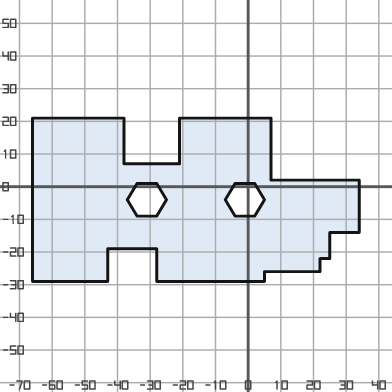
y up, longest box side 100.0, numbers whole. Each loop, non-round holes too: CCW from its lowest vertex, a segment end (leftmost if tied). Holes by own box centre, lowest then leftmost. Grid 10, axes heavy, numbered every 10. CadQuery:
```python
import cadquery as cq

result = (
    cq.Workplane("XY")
    .moveTo(-66.0, -29.0)
    .lineTo(-43.0, -29.0)
    .lineTo(-43.0, -19.0)
    .lineTo(-28.0, -19.0)
    .lineTo(-28.0, -29.0)
    .lineTo(5.0, -29.0)
    .lineTo(5.0, -26.0)
    .lineTo(22.0, -26.0)
    .lineTo(22.0, -22.0)
    .lineTo(25.0, -22.0)
    .lineTo(25.0, -14.0)
    .lineTo(34.0, -14.0)
    .lineTo(34.0, 2.0)
    .lineTo(7.0, 2.0)
    .lineTo(7.0, 21.0)
    .lineTo(-21.0, 21.0)
    .lineTo(-21.0, 7.0)
    .lineTo(-38.0, 7.0)
    .lineTo(-38.0, 21.0)
    .lineTo(-66.0, 21.0)
    .close()
    .moveTo(-34.0, -9.0)
    .lineTo(-28.0, -9.0)
    .lineTo(-25.0, -4.0)
    .lineTo(-28.0, 1.0)
    .lineTo(-34.0, 1.0)
    .lineTo(-37.0, -4.0)
    .close()
    .moveTo(-4.0, -9.0)
    .lineTo(2.0, -9.0)
    .lineTo(5.0, -4.0)
    .lineTo(2.0, 1.0)
    .lineTo(-4.0, 1.0)
    .lineTo(-7.0, -4.0)
    .close()
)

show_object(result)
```